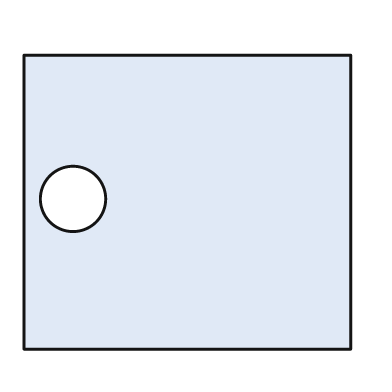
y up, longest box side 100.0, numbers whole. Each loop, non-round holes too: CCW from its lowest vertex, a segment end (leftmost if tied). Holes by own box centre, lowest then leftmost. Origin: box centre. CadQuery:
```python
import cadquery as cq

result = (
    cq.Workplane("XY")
    .moveTo(-50.0, -45.0)
    .lineTo(50.0, -45.0)
    .lineTo(50.0, 45.0)
    .lineTo(-50.0, 45.0)
    .close()
    .moveTo(-35.0, 1.0)
    .circle(10.0)
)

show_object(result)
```